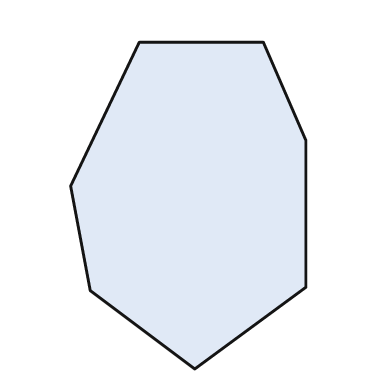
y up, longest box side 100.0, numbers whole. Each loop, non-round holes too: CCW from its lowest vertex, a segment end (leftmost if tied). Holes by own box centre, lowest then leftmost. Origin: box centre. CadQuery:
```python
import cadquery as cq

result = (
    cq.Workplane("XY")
    .moveTo(2.0, -50.0)
    .lineTo(36.0, -25.0)
    .lineTo(36.0, 20.0)
    .lineTo(23.0, 50.0)
    .lineTo(-15.0, 50.0)
    .lineTo(-36.0, 6.0)
    .lineTo(-30.0, -26.0)
    .close()
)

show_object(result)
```